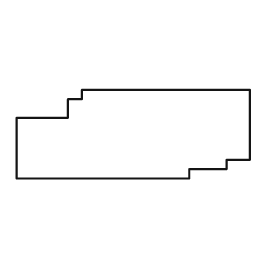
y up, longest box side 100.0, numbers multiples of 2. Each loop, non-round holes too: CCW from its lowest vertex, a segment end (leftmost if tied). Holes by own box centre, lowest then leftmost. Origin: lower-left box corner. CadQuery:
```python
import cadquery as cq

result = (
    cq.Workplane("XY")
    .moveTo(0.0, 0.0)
    .lineTo(74.0, 0.0)
    .lineTo(74.0, 4.0)
    .lineTo(90.0, 4.0)
    .lineTo(90.0, 8.0)
    .lineTo(100.0, 8.0)
    .lineTo(100.0, 38.0)
    .lineTo(28.0, 38.0)
    .lineTo(28.0, 34.0)
    .lineTo(22.0, 34.0)
    .lineTo(22.0, 26.0)
    .lineTo(0.0, 26.0)
    .close()
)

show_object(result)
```